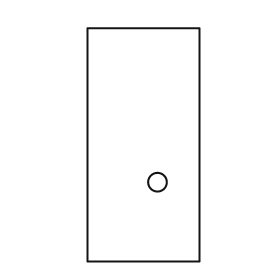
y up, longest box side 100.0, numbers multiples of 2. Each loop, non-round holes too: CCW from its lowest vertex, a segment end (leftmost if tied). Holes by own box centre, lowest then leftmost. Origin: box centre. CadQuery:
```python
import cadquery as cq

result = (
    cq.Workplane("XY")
    .moveTo(-24.0, -50.0)
    .lineTo(24.0, -50.0)
    .lineTo(24.0, 50.0)
    .lineTo(-24.0, 50.0)
    .close()
    .moveTo(6.0, -16.0)
    .circle(4.0)
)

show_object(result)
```